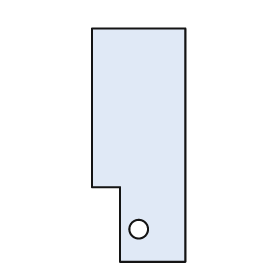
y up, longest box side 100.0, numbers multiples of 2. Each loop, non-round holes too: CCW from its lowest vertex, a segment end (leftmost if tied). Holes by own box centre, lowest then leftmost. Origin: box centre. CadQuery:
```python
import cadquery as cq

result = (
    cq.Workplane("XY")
    .moveTo(-8.0, -50.0)
    .lineTo(20.0, -50.0)
    .lineTo(20.0, 50.0)
    .lineTo(-20.0, 50.0)
    .lineTo(-20.0, -18.0)
    .lineTo(-8.0, -18.0)
    .close()
    .moveTo(0.0, -36.0)
    .circle(4.0)
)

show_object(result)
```